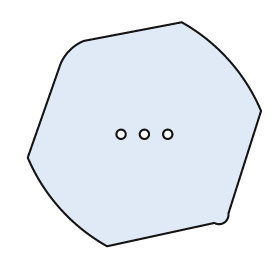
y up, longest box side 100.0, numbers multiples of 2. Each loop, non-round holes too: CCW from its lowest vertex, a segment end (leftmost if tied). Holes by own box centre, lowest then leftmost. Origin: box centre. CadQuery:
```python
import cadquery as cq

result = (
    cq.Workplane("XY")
    .moveTo(-16.0, -48.0)
    .lineTo(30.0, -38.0)
    .threePointArc((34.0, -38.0), (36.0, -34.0))
    .lineTo(50.0, 10.0)
    .threePointArc((36.0, 32.0), (16.0, 48.0))
    .lineTo(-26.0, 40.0)
    .threePointArc((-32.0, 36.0), (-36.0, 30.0))
    .lineTo(-50.0, -10.0)
    .threePointArc((-36.0, -32.0), (-16.0, -48.0))
    .close()
    .moveTo(-10.0, 0.0)
    .circle(2.0)
    .moveTo(0.0, 0.0)
    .circle(2.0)
    .moveTo(10.0, 0.0)
    .circle(2.0)
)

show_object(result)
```